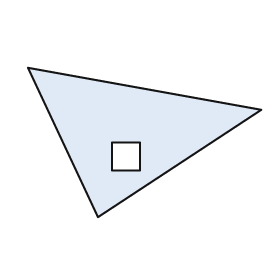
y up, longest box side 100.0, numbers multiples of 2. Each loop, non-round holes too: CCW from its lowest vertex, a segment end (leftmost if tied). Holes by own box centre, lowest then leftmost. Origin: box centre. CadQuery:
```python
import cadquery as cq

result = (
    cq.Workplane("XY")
    .moveTo(-20.0, -32.0)
    .lineTo(50.0, 14.0)
    .lineTo(-50.0, 32.0)
    .close()
    .moveTo(-14.0, -12.0)
    .lineTo(-2.0, -12.0)
    .lineTo(-2.0, 0.0)
    .lineTo(-14.0, 0.0)
    .close()
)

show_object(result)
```